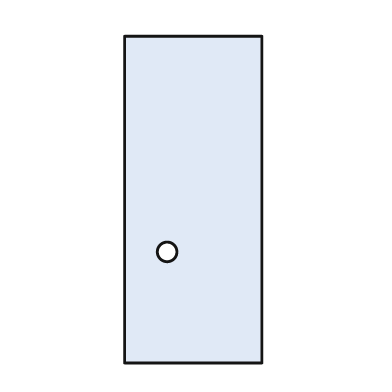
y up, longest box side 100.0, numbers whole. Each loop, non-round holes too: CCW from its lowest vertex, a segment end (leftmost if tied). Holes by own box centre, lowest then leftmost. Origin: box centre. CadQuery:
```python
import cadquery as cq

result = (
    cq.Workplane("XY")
    .moveTo(-21.0, -50.0)
    .lineTo(21.0, -50.0)
    .lineTo(21.0, 50.0)
    .lineTo(-21.0, 50.0)
    .close()
    .moveTo(-8.0, -16.0)
    .circle(3.0)
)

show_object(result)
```